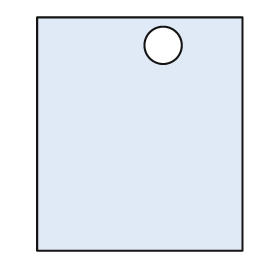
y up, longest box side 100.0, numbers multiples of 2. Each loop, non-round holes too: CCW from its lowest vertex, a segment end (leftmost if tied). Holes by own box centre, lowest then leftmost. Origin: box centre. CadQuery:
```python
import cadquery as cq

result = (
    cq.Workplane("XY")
    .moveTo(-44.0, -50.0)
    .lineTo(44.0, -50.0)
    .lineTo(44.0, 50.0)
    .lineTo(-44.0, 50.0)
    .close()
    .moveTo(10.0, 38.0)
    .circle(8.0)
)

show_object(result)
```